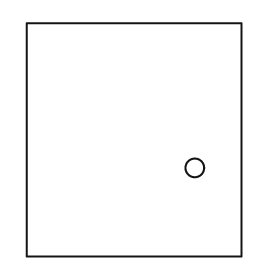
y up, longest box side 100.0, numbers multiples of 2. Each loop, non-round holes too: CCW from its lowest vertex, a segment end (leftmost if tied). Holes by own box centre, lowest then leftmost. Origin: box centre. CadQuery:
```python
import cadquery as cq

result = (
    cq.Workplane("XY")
    .moveTo(-46.0, -50.0)
    .lineTo(46.0, -50.0)
    .lineTo(46.0, 50.0)
    .lineTo(-46.0, 50.0)
    .close()
    .moveTo(26.0, -12.0)
    .circle(4.0)
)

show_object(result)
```